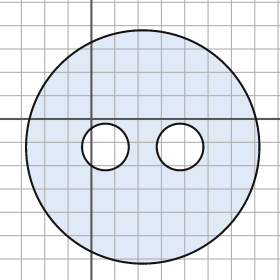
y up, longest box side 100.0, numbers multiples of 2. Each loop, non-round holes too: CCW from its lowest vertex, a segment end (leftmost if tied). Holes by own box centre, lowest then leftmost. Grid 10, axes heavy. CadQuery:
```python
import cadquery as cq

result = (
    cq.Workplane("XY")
    .moveTo(22.0, -12.0)
    .circle(50.0)
    .moveTo(6.0, -12.0)
    .circle(10.0)
    .moveTo(38.0, -12.0)
    .circle(10.0)
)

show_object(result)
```